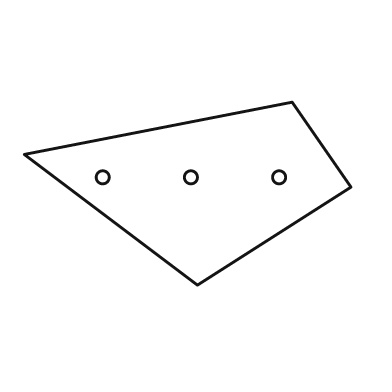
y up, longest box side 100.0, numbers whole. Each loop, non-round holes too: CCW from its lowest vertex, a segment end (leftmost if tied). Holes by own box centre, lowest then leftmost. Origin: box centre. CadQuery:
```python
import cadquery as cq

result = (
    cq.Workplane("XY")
    .moveTo(3.0, -28.0)
    .lineTo(50.0, 2.0)
    .lineTo(32.0, 28.0)
    .lineTo(-50.0, 12.0)
    .close()
    .moveTo(-26.0, 5.0)
    .circle(2.0)
    .moveTo(1.0, 5.0)
    .circle(2.0)
    .moveTo(28.0, 5.0)
    .circle(2.0)
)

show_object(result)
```